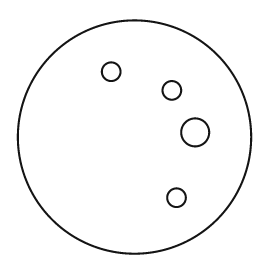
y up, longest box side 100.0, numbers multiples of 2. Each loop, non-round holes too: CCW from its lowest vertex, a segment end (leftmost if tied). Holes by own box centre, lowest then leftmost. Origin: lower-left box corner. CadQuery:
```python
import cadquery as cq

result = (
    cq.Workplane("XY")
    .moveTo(50.0, 50.0)
    .circle(50.0)
    .moveTo(68.0, 24.0)
    .circle(4.0)
    .moveTo(76.0, 52.0)
    .circle(6.0)
    .moveTo(66.0, 70.0)
    .circle(4.0)
    .moveTo(40.0, 78.0)
    .circle(4.0)
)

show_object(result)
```